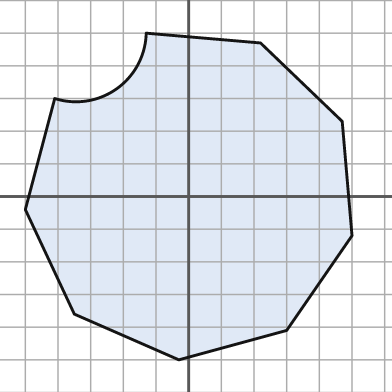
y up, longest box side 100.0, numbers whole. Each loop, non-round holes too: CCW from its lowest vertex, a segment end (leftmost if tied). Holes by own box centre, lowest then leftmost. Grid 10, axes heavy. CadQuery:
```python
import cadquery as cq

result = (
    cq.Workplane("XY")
    .moveTo(-3.0, -50.0)
    .lineTo(30.0, -41.0)
    .lineTo(50.0, -12.0)
    .lineTo(47.0, 23.0)
    .lineTo(22.0, 47.0)
    .lineTo(-13.0, 50.0)
    .threePointArc((-22.0, 33.0), (-41.0, 30.0))
    .lineTo(-50.0, -4.0)
    .lineTo(-35.0, -36.0)
    .close()
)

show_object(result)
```